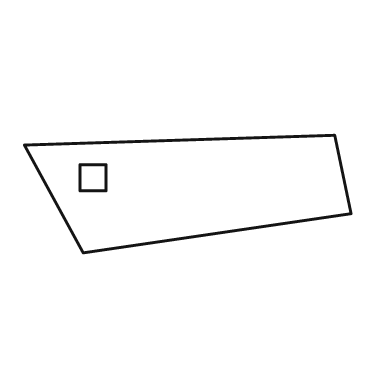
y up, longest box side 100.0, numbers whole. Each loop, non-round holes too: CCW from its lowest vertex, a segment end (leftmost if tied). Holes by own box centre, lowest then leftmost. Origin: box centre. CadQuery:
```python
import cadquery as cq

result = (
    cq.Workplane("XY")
    .moveTo(-32.0, -18.0)
    .lineTo(50.0, -6.0)
    .lineTo(45.0, 18.0)
    .lineTo(-50.0, 15.0)
    .close()
    .moveTo(-33.0, 1.0)
    .lineTo(-25.0, 1.0)
    .lineTo(-25.0, 9.0)
    .lineTo(-33.0, 9.0)
    .close()
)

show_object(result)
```